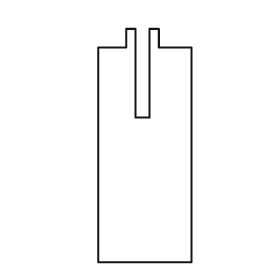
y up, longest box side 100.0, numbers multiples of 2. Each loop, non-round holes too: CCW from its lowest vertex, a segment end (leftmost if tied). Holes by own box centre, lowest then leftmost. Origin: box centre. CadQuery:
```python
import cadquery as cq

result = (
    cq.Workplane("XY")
    .moveTo(-20.0, -50.0)
    .lineTo(20.0, -50.0)
    .lineTo(20.0, 42.0)
    .lineTo(6.0, 42.0)
    .lineTo(6.0, 50.0)
    .lineTo(2.0, 50.0)
    .lineTo(2.0, 12.0)
    .lineTo(-4.0, 12.0)
    .lineTo(-4.0, 50.0)
    .lineTo(-8.0, 50.0)
    .lineTo(-8.0, 42.0)
    .lineTo(-20.0, 42.0)
    .close()
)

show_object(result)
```